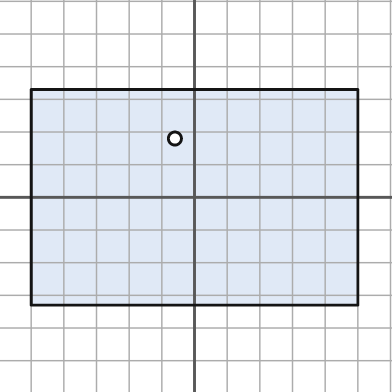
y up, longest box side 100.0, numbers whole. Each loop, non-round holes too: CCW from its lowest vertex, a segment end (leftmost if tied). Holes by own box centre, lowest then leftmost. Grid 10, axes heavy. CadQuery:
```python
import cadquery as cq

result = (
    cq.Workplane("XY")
    .moveTo(-50.0, -33.0)
    .lineTo(50.0, -33.0)
    .lineTo(50.0, 33.0)
    .lineTo(-50.0, 33.0)
    .close()
    .moveTo(-6.0, 18.0)
    .circle(2.0)
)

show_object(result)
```